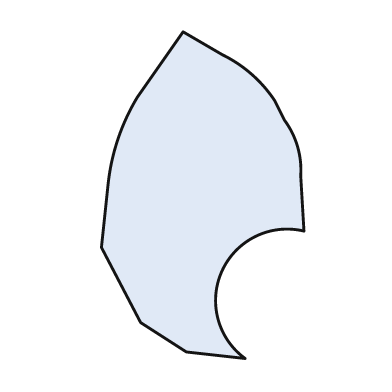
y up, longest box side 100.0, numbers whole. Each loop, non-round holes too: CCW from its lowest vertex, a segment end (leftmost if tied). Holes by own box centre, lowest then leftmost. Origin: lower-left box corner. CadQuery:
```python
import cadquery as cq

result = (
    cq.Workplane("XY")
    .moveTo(44.0, 0.0)
    .threePointArc((37.0, 27.0), (62.0, 39.0))
    .lineTo(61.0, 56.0)
    .threePointArc((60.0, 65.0), (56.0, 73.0))
    .lineTo(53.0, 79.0)
    .threePointArc((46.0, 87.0), (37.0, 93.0))
    .lineTo(25.0, 100.0)
    .lineTo(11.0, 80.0)
    .threePointArc((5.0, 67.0), (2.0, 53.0))
    .lineTo(0.0, 34.0)
    .lineTo(12.0, 11.0)
    .lineTo(26.0, 2.0)
    .close()
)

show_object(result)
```